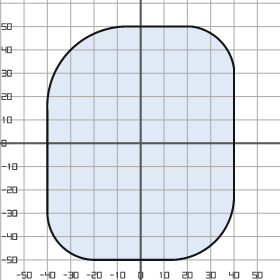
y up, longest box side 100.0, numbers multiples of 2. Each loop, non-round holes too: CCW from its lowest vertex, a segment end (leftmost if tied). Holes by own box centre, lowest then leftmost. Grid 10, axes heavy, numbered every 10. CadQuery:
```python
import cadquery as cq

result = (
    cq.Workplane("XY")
    .moveTo(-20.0, -50.0)
    .lineTo(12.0, -50.0)
    .threePointArc((32.0, -42.0), (40.0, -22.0))
    .lineTo(40.0, 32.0)
    .threePointArc((34.0, 44.0), (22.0, 50.0))
    .lineTo(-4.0, 50.0)
    .threePointArc((-30.0, 40.0), (-40.0, 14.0))
    .lineTo(-40.0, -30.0)
    .threePointArc((-34.0, -44.0), (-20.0, -50.0))
    .close()
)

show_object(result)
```